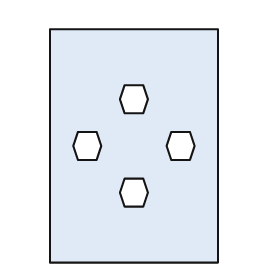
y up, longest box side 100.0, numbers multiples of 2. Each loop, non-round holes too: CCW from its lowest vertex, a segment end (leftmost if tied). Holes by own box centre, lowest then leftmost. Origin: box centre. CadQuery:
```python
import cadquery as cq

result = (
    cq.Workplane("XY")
    .moveTo(-36.0, -50.0)
    .lineTo(36.0, -50.0)
    .lineTo(36.0, 50.0)
    .lineTo(-36.0, 50.0)
    .close()
    .moveTo(-4.0, -26.0)
    .lineTo(4.0, -26.0)
    .lineTo(6.0, -20.0)
    .lineTo(4.0, -14.0)
    .lineTo(-4.0, -14.0)
    .lineTo(-6.0, -20.0)
    .close()
    .moveTo(-24.0, -6.0)
    .lineTo(-16.0, -6.0)
    .lineTo(-14.0, 0.0)
    .lineTo(-16.0, 6.0)
    .lineTo(-24.0, 6.0)
    .lineTo(-26.0, 0.0)
    .close()
    .moveTo(16.0, -6.0)
    .lineTo(24.0, -6.0)
    .lineTo(26.0, 0.0)
    .lineTo(24.0, 6.0)
    .lineTo(16.0, 6.0)
    .lineTo(14.0, 0.0)
    .close()
    .moveTo(-4.0, 14.0)
    .lineTo(4.0, 14.0)
    .lineTo(6.0, 20.0)
    .lineTo(4.0, 26.0)
    .lineTo(-4.0, 26.0)
    .lineTo(-6.0, 20.0)
    .close()
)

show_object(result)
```